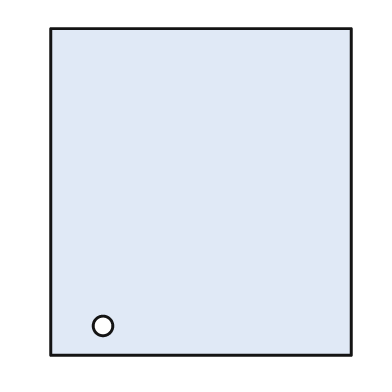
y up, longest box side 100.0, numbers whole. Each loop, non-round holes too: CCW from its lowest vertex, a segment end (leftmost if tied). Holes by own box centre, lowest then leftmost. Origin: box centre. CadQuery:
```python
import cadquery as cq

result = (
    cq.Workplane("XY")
    .moveTo(-46.0, -50.0)
    .lineTo(46.0, -50.0)
    .lineTo(46.0, 50.0)
    .lineTo(-46.0, 50.0)
    .close()
    .moveTo(-30.0, -41.0)
    .circle(3.0)
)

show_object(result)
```